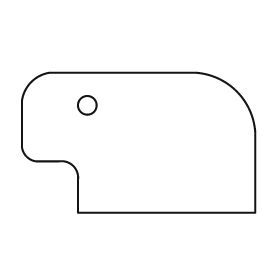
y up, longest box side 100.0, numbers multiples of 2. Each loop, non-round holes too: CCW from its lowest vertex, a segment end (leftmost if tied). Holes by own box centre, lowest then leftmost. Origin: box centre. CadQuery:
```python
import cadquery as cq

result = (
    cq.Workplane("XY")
    .moveTo(-26.0, -30.0)
    .lineTo(50.0, -30.0)
    .lineTo(50.0, 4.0)
    .threePointArc((42.0, 22.0), (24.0, 30.0))
    .lineTo(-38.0, 30.0)
    .threePointArc((-46.0, 26.0), (-50.0, 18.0))
    .lineTo(-50.0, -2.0)
    .threePointArc((-48.0, -6.0), (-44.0, -8.0))
    .lineTo(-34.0, -8.0)
    .threePointArc((-28.0, -10.0), (-26.0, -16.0))
    .close()
    .moveTo(-22.0, 16.0)
    .circle(4.0)
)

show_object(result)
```